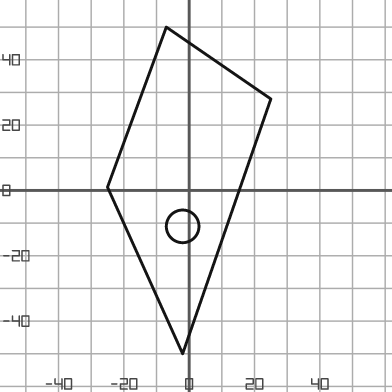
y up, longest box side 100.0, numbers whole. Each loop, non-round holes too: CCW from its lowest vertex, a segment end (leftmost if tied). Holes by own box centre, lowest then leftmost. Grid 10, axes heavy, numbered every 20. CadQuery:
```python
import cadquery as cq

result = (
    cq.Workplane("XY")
    .moveTo(-2.0, -50.0)
    .lineTo(25.0, 28.0)
    .lineTo(-7.0, 50.0)
    .lineTo(-25.0, 1.0)
    .close()
    .moveTo(-2.0, -11.0)
    .circle(5.0)
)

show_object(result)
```